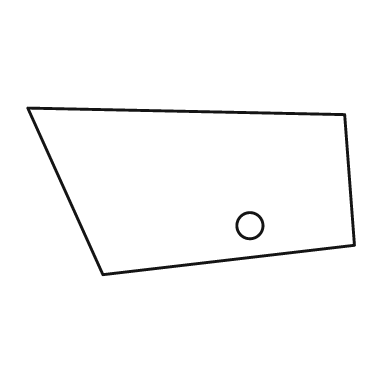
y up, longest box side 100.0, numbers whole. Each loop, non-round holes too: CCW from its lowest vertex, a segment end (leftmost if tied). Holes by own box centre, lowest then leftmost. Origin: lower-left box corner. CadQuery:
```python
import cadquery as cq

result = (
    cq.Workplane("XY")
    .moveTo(23.0, 0.0)
    .lineTo(100.0, 9.0)
    .lineTo(97.0, 49.0)
    .lineTo(0.0, 51.0)
    .close()
    .moveTo(68.0, 15.0)
    .circle(4.0)
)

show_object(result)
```